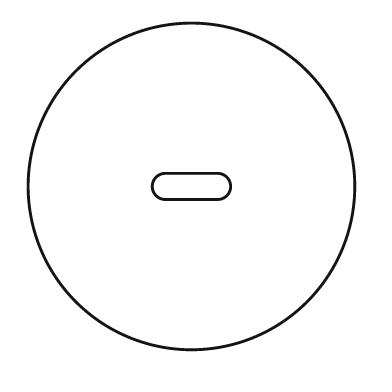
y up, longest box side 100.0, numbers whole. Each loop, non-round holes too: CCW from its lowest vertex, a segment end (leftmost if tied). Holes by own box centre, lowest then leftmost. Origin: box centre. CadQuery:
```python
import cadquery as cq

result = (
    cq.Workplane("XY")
    .moveTo(0.0, 0.0)
    .circle(50.0)
    .moveTo(-8.0, -4.0)
    .lineTo(8.0, -4.0)
    .threePointArc((12.0, 0.0), (8.0, 4.0))
    .lineTo(-8.0, 4.0)
    .threePointArc((-12.0, 0.0), (-8.0, -4.0))
    .close()
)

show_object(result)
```